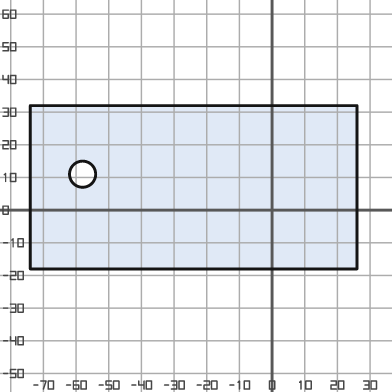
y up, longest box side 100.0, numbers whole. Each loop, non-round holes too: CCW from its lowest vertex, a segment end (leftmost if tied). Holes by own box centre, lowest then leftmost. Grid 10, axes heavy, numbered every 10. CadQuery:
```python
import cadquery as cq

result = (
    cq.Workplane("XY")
    .moveTo(-74.0, -18.0)
    .lineTo(26.0, -18.0)
    .lineTo(26.0, 32.0)
    .lineTo(-74.0, 32.0)
    .close()
    .moveTo(-58.0, 11.0)
    .circle(4.0)
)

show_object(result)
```